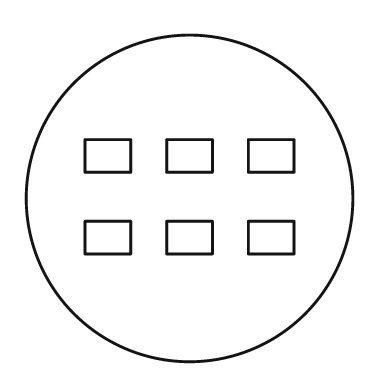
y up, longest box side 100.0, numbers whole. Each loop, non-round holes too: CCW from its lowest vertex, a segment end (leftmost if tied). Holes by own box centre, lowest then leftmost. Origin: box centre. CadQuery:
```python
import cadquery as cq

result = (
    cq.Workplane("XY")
    .moveTo(0.0, 0.0)
    .circle(50.0)
    .moveTo(-32.0, -17.0)
    .lineTo(-18.0, -17.0)
    .lineTo(-18.0, -7.0)
    .lineTo(-32.0, -7.0)
    .close()
    .moveTo(-7.0, -17.0)
    .lineTo(7.0, -17.0)
    .lineTo(7.0, -7.0)
    .lineTo(-7.0, -7.0)
    .close()
    .moveTo(18.0, -17.0)
    .lineTo(32.0, -17.0)
    .lineTo(32.0, -7.0)
    .lineTo(18.0, -7.0)
    .close()
    .moveTo(-32.0, 8.0)
    .lineTo(-18.0, 8.0)
    .lineTo(-18.0, 18.0)
    .lineTo(-32.0, 18.0)
    .close()
    .moveTo(-7.0, 8.0)
    .lineTo(7.0, 8.0)
    .lineTo(7.0, 18.0)
    .lineTo(-7.0, 18.0)
    .close()
    .moveTo(18.0, 8.0)
    .lineTo(32.0, 8.0)
    .lineTo(32.0, 18.0)
    .lineTo(18.0, 18.0)
    .close()
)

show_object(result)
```